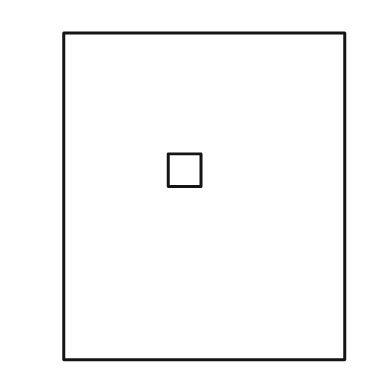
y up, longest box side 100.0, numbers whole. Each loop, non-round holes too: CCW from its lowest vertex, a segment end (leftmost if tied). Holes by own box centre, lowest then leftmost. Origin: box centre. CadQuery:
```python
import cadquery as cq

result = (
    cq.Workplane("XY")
    .moveTo(-43.0, -50.0)
    .lineTo(43.0, -50.0)
    .lineTo(43.0, 50.0)
    .lineTo(-43.0, 50.0)
    .close()
    .moveTo(-11.0, 3.0)
    .lineTo(-1.0, 3.0)
    .lineTo(-1.0, 13.0)
    .lineTo(-11.0, 13.0)
    .close()
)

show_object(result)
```